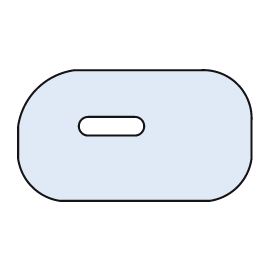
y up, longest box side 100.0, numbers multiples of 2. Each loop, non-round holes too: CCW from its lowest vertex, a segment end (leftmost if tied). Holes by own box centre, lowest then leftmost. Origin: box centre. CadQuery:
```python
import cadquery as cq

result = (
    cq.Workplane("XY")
    .moveTo(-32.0, -28.0)
    .lineTo(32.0, -28.0)
    .threePointArc((44.0, -22.0), (50.0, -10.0))
    .lineTo(50.0, 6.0)
    .threePointArc((44.0, 22.0), (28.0, 28.0))
    .lineTo(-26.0, 28.0)
    .threePointArc((-42.0, 20.0), (-50.0, 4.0))
    .lineTo(-50.0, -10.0)
    .threePointArc((-44.0, -22.0), (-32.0, -28.0))
    .close()
    .moveTo(-20.0, 0.0)
    .lineTo(0.0, 0.0)
    .threePointArc((4.0, 4.0), (0.0, 8.0))
    .lineTo(-20.0, 8.0)
    .threePointArc((-24.0, 4.0), (-20.0, 0.0))
    .close()
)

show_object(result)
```